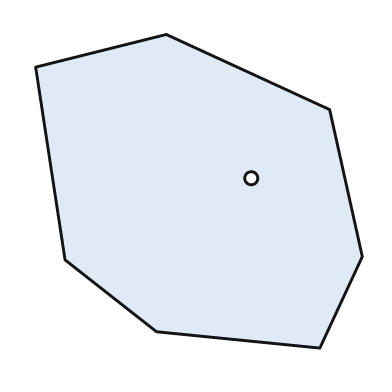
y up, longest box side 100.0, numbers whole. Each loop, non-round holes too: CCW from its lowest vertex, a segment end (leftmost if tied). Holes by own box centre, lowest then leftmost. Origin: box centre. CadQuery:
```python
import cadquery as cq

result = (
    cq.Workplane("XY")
    .moveTo(37.0, -48.0)
    .lineTo(50.0, -20.0)
    .lineTo(40.0, 25.0)
    .lineTo(-10.0, 48.0)
    .lineTo(-50.0, 38.0)
    .lineTo(-41.0, -21.0)
    .lineTo(-13.0, -43.0)
    .close()
    .moveTo(16.0, 4.0)
    .circle(2.0)
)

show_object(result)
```